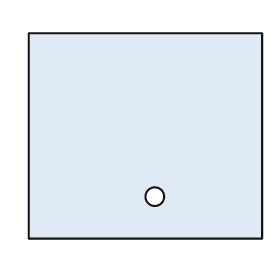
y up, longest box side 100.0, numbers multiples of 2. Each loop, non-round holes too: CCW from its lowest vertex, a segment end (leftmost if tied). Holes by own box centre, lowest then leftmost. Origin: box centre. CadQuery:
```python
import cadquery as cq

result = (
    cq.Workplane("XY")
    .moveTo(-50.0, -44.0)
    .lineTo(50.0, -44.0)
    .lineTo(50.0, 44.0)
    .lineTo(-50.0, 44.0)
    .close()
    .moveTo(4.0, -26.0)
    .circle(4.0)
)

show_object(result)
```